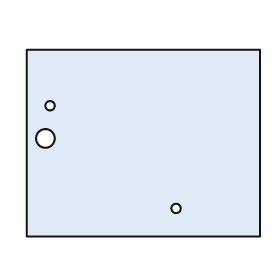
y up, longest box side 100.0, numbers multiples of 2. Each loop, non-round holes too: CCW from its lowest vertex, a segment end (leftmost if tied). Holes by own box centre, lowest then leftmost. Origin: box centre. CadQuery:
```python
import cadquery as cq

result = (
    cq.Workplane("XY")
    .moveTo(-50.0, -40.0)
    .lineTo(50.0, -40.0)
    .lineTo(50.0, 40.0)
    .lineTo(-50.0, 40.0)
    .close()
    .moveTo(14.0, -28.0)
    .circle(2.0)
    .moveTo(-42.0, 2.0)
    .circle(4.0)
    .moveTo(-40.0, 16.0)
    .circle(2.0)
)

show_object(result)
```